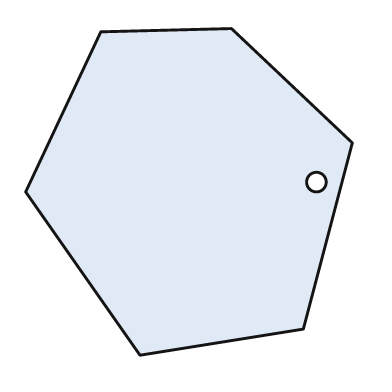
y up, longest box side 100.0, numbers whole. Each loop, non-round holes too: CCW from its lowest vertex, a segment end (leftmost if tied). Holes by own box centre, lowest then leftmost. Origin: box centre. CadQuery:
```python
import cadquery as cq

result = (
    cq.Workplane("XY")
    .moveTo(-15.0, -50.0)
    .lineTo(35.0, -42.0)
    .lineTo(50.0, 15.0)
    .lineTo(13.0, 50.0)
    .lineTo(-27.0, 49.0)
    .lineTo(-50.0, 0.0)
    .close()
    .moveTo(39.0, 3.0)
    .circle(3.0)
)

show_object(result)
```